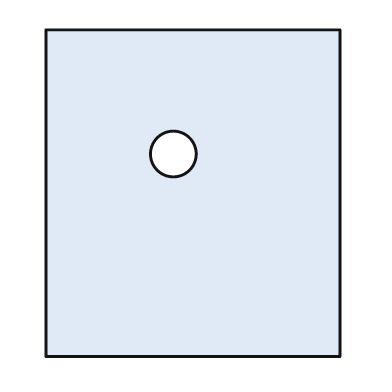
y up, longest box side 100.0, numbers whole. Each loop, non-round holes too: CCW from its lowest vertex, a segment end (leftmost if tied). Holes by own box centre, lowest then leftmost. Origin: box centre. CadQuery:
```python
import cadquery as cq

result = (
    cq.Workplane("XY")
    .moveTo(-45.0, -50.0)
    .lineTo(45.0, -50.0)
    .lineTo(45.0, 50.0)
    .lineTo(-45.0, 50.0)
    .close()
    .moveTo(-6.0, 12.0)
    .circle(7.0)
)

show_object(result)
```